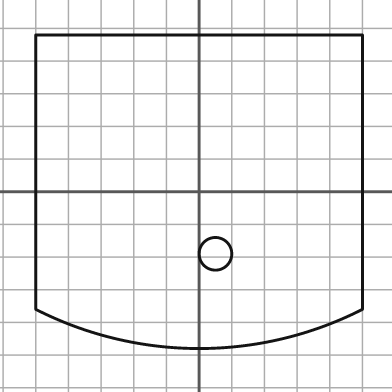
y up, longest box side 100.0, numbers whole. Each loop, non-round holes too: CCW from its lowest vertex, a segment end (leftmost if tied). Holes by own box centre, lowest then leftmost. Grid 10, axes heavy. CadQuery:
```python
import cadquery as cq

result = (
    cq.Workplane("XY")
    .moveTo(-50.0, -36.0)
    .threePointArc((0.0, -48.0), (50.0, -36.0))
    .lineTo(50.0, 48.0)
    .lineTo(-50.0, 48.0)
    .close()
    .moveTo(5.0, -19.0)
    .circle(5.0)
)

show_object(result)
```